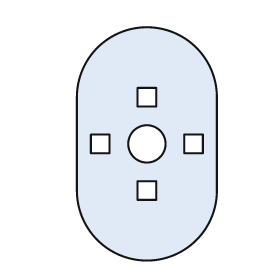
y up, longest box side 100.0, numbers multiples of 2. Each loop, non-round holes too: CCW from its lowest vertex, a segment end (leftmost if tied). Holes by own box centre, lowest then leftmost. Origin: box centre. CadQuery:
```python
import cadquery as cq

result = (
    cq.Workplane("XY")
    .moveTo(-30.0, -20.0)
    .threePointArc((0.0, -50.0), (30.0, -20.0))
    .lineTo(30.0, 20.0)
    .threePointArc((0.0, 50.0), (-30.0, 20.0))
    .close()
    .moveTo(-4.0, -24.0)
    .lineTo(4.0, -24.0)
    .lineTo(4.0, -16.0)
    .lineTo(-4.0, -16.0)
    .close()
    .moveTo(-24.0, -4.0)
    .lineTo(-16.0, -4.0)
    .lineTo(-16.0, 4.0)
    .lineTo(-24.0, 4.0)
    .close()
    .moveTo(0.0, 0.0)
    .circle(8.0)
    .moveTo(16.0, -4.0)
    .lineTo(24.0, -4.0)
    .lineTo(24.0, 4.0)
    .lineTo(16.0, 4.0)
    .close()
    .moveTo(-4.0, 16.0)
    .lineTo(4.0, 16.0)
    .lineTo(4.0, 24.0)
    .lineTo(-4.0, 24.0)
    .close()
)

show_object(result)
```